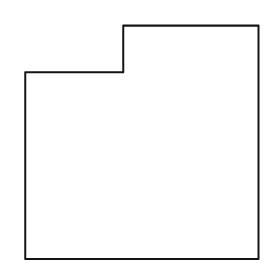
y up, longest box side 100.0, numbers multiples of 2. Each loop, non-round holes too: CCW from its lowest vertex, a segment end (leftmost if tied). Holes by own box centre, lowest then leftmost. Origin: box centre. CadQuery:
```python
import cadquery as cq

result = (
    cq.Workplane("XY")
    .moveTo(-50.0, -50.0)
    .lineTo(50.0, -50.0)
    .lineTo(50.0, 50.0)
    .lineTo(-8.0, 50.0)
    .lineTo(-8.0, 30.0)
    .lineTo(-50.0, 30.0)
    .close()
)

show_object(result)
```